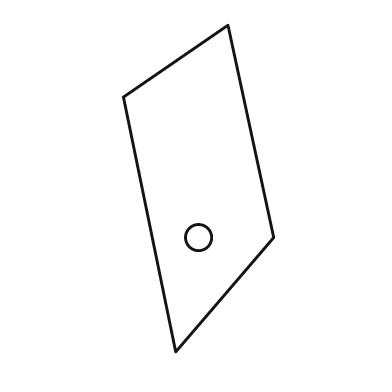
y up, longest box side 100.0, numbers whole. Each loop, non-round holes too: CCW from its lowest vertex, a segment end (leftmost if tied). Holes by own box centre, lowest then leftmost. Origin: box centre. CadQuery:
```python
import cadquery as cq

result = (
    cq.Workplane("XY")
    .moveTo(-7.0, -50.0)
    .lineTo(23.0, -15.0)
    .lineTo(9.0, 50.0)
    .lineTo(-23.0, 28.0)
    .close()
    .moveTo(0.0, -15.0)
    .circle(4.0)
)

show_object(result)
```